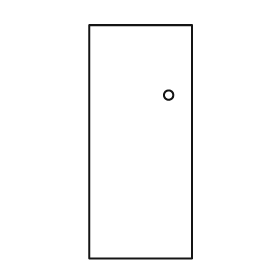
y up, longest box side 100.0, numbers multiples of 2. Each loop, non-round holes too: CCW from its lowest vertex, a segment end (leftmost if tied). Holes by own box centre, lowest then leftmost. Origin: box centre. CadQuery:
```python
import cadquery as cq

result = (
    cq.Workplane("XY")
    .moveTo(-22.0, -50.0)
    .lineTo(22.0, -50.0)
    .lineTo(22.0, 50.0)
    .lineTo(-22.0, 50.0)
    .close()
    .moveTo(12.0, 20.0)
    .circle(2.0)
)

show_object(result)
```